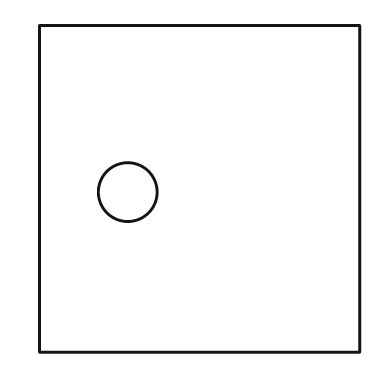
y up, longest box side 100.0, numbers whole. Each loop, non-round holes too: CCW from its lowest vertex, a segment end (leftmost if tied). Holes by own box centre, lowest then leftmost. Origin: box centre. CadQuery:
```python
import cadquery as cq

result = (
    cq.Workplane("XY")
    .moveTo(-49.0, -50.0)
    .lineTo(49.0, -50.0)
    .lineTo(49.0, 50.0)
    .lineTo(-49.0, 50.0)
    .close()
    .moveTo(-22.0, -1.0)
    .circle(9.0)
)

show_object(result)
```